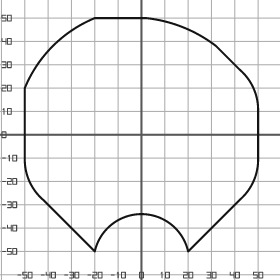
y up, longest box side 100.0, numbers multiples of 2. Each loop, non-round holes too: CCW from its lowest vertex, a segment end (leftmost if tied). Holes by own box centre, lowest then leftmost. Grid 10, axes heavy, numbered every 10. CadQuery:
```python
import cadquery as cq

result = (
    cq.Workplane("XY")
    .moveTo(-20.0, -50.0)
    .threePointArc((0.0, -34.0), (20.0, -50.0))
    .lineTo(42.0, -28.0)
    .threePointArc((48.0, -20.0), (50.0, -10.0))
    .lineTo(50.0, 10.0)
    .threePointArc((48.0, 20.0), (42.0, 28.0))
    .lineTo(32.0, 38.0)
    .threePointArc((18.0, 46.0), (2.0, 50.0))
    .lineTo(-20.0, 50.0)
    .threePointArc((-38.0, 38.0), (-50.0, 20.0))
    .lineTo(-50.0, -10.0)
    .threePointArc((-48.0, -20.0), (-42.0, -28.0))
    .close()
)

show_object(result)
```